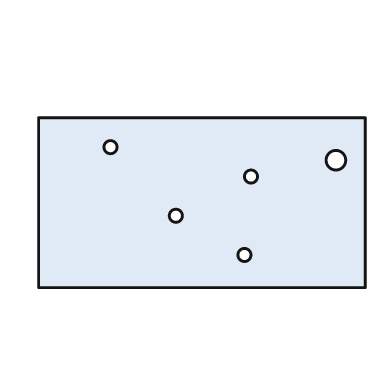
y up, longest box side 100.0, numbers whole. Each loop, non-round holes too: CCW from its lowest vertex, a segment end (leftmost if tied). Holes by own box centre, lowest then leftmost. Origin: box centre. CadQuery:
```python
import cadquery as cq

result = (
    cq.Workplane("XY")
    .moveTo(-50.0, -26.0)
    .lineTo(50.0, -26.0)
    .lineTo(50.0, 26.0)
    .lineTo(-50.0, 26.0)
    .close()
    .moveTo(13.0, -16.0)
    .circle(2.0)
    .moveTo(-8.0, -4.0)
    .circle(2.0)
    .moveTo(15.0, 8.0)
    .circle(2.0)
    .moveTo(41.0, 13.0)
    .circle(3.0)
    .moveTo(-28.0, 17.0)
    .circle(2.0)
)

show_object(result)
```